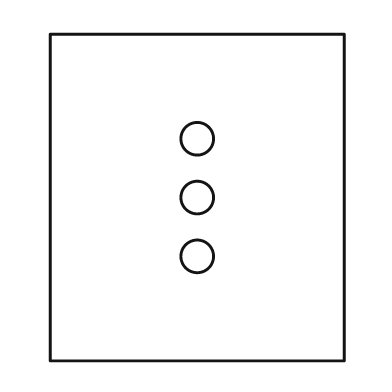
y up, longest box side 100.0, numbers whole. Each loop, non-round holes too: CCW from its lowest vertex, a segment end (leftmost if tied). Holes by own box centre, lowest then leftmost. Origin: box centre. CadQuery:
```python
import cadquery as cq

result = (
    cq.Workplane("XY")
    .moveTo(-45.0, -50.0)
    .lineTo(45.0, -50.0)
    .lineTo(45.0, 50.0)
    .lineTo(-45.0, 50.0)
    .close()
    .moveTo(0.0, -18.0)
    .circle(5.0)
    .moveTo(0.0, 0.0)
    .circle(5.0)
    .moveTo(0.0, 18.0)
    .circle(5.0)
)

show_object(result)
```